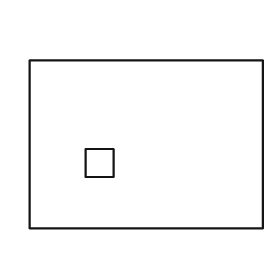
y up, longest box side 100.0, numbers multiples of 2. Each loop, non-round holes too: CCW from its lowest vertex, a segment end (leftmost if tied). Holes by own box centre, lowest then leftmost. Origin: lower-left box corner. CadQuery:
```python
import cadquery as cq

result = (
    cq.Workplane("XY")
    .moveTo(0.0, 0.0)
    .lineTo(100.0, 0.0)
    .lineTo(100.0, 72.0)
    .lineTo(0.0, 72.0)
    .close()
    .moveTo(24.0, 22.0)
    .lineTo(36.0, 22.0)
    .lineTo(36.0, 34.0)
    .lineTo(24.0, 34.0)
    .close()
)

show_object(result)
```